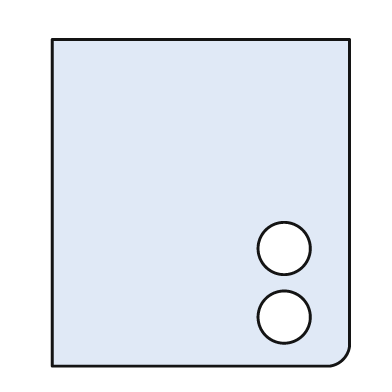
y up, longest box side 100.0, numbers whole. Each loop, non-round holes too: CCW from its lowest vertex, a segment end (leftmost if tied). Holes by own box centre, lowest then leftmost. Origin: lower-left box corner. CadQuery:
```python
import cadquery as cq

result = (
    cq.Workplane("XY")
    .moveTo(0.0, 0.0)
    .lineTo(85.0, 0.0)
    .threePointArc((89.0, 2.0), (91.0, 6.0))
    .lineTo(91.0, 100.0)
    .lineTo(0.0, 100.0)
    .close()
    .moveTo(71.0, 15.0)
    .circle(8.0)
    .moveTo(71.0, 36.0)
    .circle(8.0)
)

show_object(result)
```